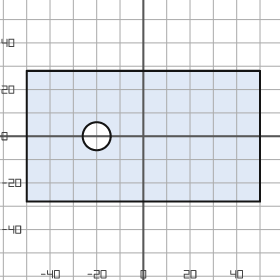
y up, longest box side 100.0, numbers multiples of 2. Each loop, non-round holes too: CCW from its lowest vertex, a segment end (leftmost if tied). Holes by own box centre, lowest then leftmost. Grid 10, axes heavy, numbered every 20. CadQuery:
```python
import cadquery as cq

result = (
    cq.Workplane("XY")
    .moveTo(-50.0, -28.0)
    .lineTo(50.0, -28.0)
    .lineTo(50.0, 28.0)
    .lineTo(-50.0, 28.0)
    .close()
    .moveTo(-20.0, 0.0)
    .circle(6.0)
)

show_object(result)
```